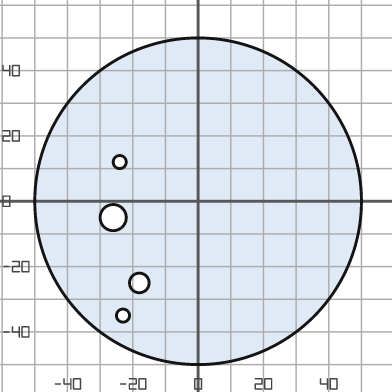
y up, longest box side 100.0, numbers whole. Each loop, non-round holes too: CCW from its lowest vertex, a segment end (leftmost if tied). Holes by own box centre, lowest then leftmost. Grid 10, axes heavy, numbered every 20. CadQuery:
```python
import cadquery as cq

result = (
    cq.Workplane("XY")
    .moveTo(0.0, 0.0)
    .circle(50.0)
    .moveTo(-23.0, -35.0)
    .circle(2.0)
    .moveTo(-18.0, -25.0)
    .circle(3.0)
    .moveTo(-26.0, -5.0)
    .circle(4.0)
    .moveTo(-24.0, 12.0)
    .circle(2.0)
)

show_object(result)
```